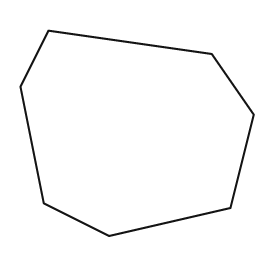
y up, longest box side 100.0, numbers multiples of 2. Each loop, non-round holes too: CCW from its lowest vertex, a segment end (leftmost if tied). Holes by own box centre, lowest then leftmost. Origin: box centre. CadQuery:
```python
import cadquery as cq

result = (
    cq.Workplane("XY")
    .moveTo(-12.0, -44.0)
    .lineTo(40.0, -32.0)
    .lineTo(50.0, 8.0)
    .lineTo(32.0, 34.0)
    .lineTo(-38.0, 44.0)
    .lineTo(-50.0, 20.0)
    .lineTo(-40.0, -30.0)
    .close()
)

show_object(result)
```